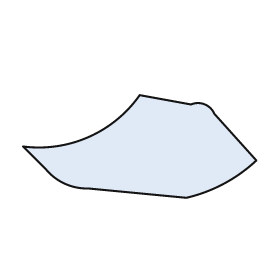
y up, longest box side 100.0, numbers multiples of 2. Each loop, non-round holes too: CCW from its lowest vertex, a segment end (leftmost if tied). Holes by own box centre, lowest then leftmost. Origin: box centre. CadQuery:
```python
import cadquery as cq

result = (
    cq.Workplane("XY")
    .moveTo(20.0, -22.0)
    .threePointArc((36.0, -16.0), (50.0, -6.0))
    .lineTo(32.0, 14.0)
    .threePointArc((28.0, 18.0), (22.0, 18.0))
    .lineTo(0.0, 22.0)
    .threePointArc((-22.0, 4.0), (-50.0, 0.0))
    .lineTo(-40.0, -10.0)
    .threePointArc((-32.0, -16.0), (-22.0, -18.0))
    .close()
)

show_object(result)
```